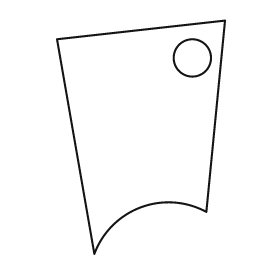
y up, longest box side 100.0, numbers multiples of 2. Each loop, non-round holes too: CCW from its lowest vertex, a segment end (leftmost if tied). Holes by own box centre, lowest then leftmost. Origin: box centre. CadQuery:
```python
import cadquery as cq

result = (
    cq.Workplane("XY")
    .moveTo(-20.0, -50.0)
    .threePointArc((0.0, -30.0), (28.0, -32.0))
    .lineTo(36.0, 50.0)
    .lineTo(-36.0, 42.0)
    .close()
    .moveTo(22.0, 34.0)
    .circle(8.0)
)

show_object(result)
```